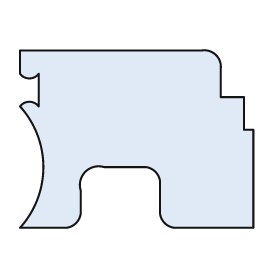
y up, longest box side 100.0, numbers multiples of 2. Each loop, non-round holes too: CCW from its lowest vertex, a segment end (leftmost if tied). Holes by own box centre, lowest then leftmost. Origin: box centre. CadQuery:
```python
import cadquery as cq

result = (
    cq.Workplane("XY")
    .moveTo(-50.0, -38.0)
    .lineTo(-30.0, -38.0)
    .threePointArc((-26.0, -36.0), (-24.0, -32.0))
    .lineTo(-24.0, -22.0)
    .threePointArc((-22.0, -14.0), (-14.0, -12.0))
    .lineTo(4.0, -12.0)
    .threePointArc((8.0, -14.0), (10.0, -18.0))
    .lineTo(10.0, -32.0)
    .threePointArc((12.0, -36.0), (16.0, -38.0))
    .lineTo(50.0, -38.0)
    .lineTo(50.0, 4.0)
    .lineTo(46.0, 4.0)
    .lineTo(46.0, 18.0)
    .lineTo(36.0, 18.0)
    .lineTo(36.0, 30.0)
    .threePointArc((34.0, 36.0), (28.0, 38.0))
    .lineTo(-50.0, 38.0)
    .lineTo(-50.0, 28.0)
    .threePointArc((-46.0, 26.0), (-42.0, 28.0))
    .lineTo(-42.0, 14.0)
    .threePointArc((-46.0, 16.0), (-50.0, 14.0))
    .threePointArc((-40.0, -12.0), (-50.0, -38.0))
    .close()
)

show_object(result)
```